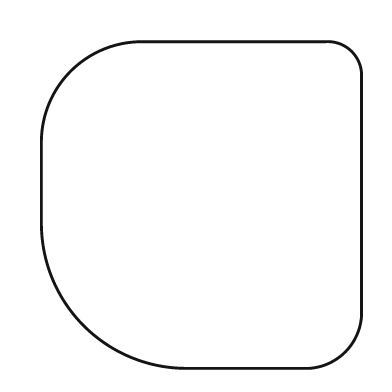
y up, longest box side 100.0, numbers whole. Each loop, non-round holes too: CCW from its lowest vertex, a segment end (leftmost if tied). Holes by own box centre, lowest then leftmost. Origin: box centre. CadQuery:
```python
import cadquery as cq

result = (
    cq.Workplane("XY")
    .moveTo(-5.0, -50.0)
    .lineTo(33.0, -50.0)
    .threePointArc((44.0, -45.0), (49.0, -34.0))
    .lineTo(49.0, 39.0)
    .threePointArc((46.0, 47.0), (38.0, 50.0))
    .lineTo(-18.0, 50.0)
    .threePointArc((-40.0, 41.0), (-49.0, 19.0))
    .lineTo(-49.0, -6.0)
    .threePointArc((-36.0, -37.0), (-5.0, -50.0))
    .close()
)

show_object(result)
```